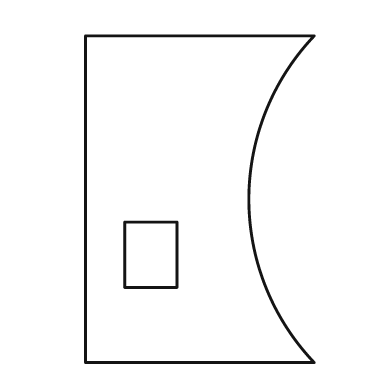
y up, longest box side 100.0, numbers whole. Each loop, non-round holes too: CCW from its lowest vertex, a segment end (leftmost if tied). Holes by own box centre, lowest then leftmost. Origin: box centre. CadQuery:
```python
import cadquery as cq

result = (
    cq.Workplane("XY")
    .moveTo(-35.0, -50.0)
    .lineTo(35.0, -50.0)
    .threePointArc((15.0, 0.0), (35.0, 50.0))
    .lineTo(-35.0, 50.0)
    .close()
    .moveTo(-23.0, -27.0)
    .lineTo(-7.0, -27.0)
    .lineTo(-7.0, -7.0)
    .lineTo(-23.0, -7.0)
    .close()
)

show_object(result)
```